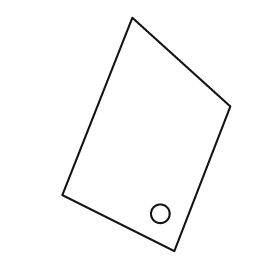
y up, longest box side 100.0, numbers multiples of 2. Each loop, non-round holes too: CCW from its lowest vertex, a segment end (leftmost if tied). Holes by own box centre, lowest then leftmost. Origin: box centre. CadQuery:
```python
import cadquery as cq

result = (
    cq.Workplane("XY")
    .moveTo(12.0, -50.0)
    .lineTo(36.0, 12.0)
    .lineTo(-6.0, 50.0)
    .lineTo(-36.0, -26.0)
    .close()
    .moveTo(6.0, -34.0)
    .circle(4.0)
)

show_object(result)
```